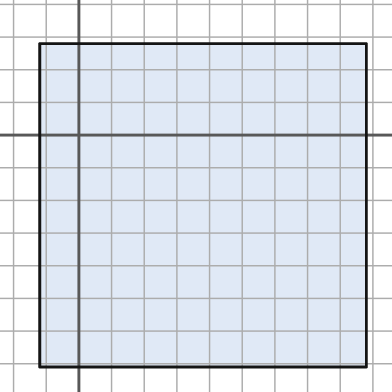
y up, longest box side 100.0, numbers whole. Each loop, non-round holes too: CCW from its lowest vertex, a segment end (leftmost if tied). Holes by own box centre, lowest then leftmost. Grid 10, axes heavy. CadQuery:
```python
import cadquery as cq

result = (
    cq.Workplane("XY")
    .moveTo(-12.0, -71.0)
    .lineTo(88.0, -71.0)
    .lineTo(88.0, 28.0)
    .lineTo(-12.0, 28.0)
    .close()
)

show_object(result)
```